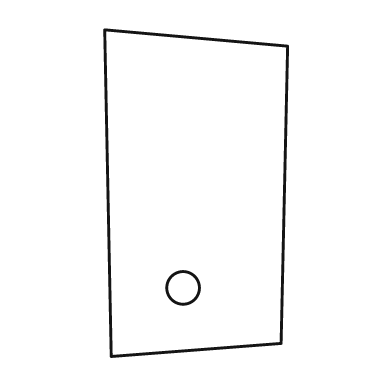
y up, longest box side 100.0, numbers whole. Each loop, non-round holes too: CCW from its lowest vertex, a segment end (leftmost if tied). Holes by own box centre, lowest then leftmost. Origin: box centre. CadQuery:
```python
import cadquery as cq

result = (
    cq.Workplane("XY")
    .moveTo(-26.0, -50.0)
    .lineTo(26.0, -46.0)
    .lineTo(28.0, 45.0)
    .lineTo(-28.0, 50.0)
    .close()
    .moveTo(-4.0, -29.0)
    .circle(5.0)
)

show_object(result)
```